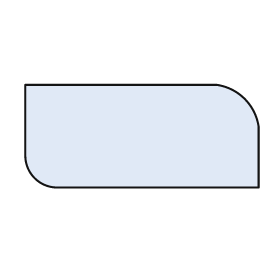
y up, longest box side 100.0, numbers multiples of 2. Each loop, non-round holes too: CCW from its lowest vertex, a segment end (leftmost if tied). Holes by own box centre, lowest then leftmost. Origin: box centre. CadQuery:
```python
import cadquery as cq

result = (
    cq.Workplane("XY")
    .moveTo(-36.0, -22.0)
    .lineTo(50.0, -22.0)
    .lineTo(50.0, 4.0)
    .threePointArc((44.0, 16.0), (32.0, 22.0))
    .lineTo(-50.0, 22.0)
    .lineTo(-50.0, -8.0)
    .threePointArc((-46.0, -18.0), (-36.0, -22.0))
    .close()
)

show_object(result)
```